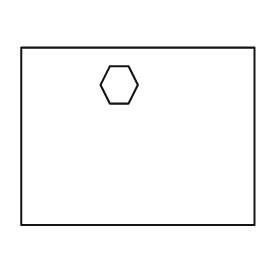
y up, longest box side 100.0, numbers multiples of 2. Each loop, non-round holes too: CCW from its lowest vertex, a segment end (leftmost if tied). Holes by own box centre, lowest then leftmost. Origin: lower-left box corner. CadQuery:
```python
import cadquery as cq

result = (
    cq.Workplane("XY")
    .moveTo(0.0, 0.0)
    .lineTo(100.0, 0.0)
    .lineTo(100.0, 76.0)
    .lineTo(0.0, 76.0)
    .close()
    .moveTo(38.0, 52.0)
    .lineTo(46.0, 52.0)
    .lineTo(50.0, 60.0)
    .lineTo(46.0, 68.0)
    .lineTo(38.0, 68.0)
    .lineTo(34.0, 60.0)
    .close()
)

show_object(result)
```